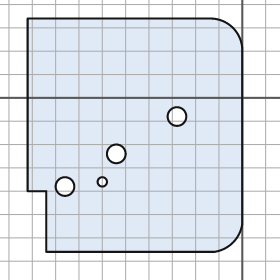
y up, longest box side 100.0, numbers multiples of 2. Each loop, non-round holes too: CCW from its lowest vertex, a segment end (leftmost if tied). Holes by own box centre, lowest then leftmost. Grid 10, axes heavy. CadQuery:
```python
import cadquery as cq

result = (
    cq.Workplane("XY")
    .moveTo(-84.0, -66.0)
    .lineTo(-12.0, -66.0)
    .threePointArc((-4.0, -62.0), (0.0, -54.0))
    .lineTo(0.0, 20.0)
    .threePointArc((-4.0, 30.0), (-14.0, 34.0))
    .lineTo(-92.0, 34.0)
    .lineTo(-92.0, -40.0)
    .lineTo(-84.0, -40.0)
    .close()
    .moveTo(-76.0, -38.0)
    .circle(4.0)
    .moveTo(-60.0, -36.0)
    .circle(2.0)
    .moveTo(-54.0, -24.0)
    .circle(4.0)
    .moveTo(-28.0, -8.0)
    .circle(4.0)
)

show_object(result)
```